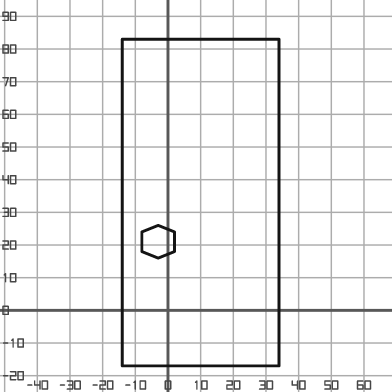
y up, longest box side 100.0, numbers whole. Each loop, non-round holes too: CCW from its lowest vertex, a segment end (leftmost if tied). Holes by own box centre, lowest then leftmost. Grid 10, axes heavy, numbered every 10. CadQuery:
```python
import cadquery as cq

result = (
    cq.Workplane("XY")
    .moveTo(-14.0, -17.0)
    .lineTo(34.0, -17.0)
    .lineTo(34.0, 83.0)
    .lineTo(-14.0, 83.0)
    .close()
    .moveTo(-3.0, 16.0)
    .lineTo(2.0, 18.0)
    .lineTo(2.0, 24.0)
    .lineTo(-3.0, 26.0)
    .lineTo(-8.0, 24.0)
    .lineTo(-8.0, 18.0)
    .close()
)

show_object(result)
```